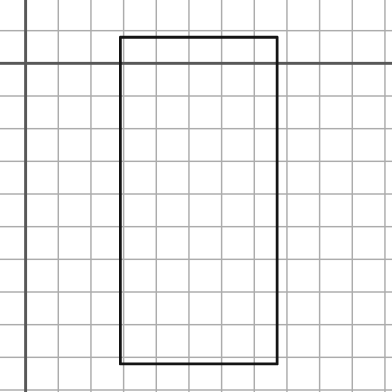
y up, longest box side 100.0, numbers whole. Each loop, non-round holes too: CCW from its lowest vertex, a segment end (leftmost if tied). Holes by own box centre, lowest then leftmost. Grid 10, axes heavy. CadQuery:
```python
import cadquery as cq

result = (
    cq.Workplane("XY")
    .moveTo(29.0, -92.0)
    .lineTo(77.0, -92.0)
    .lineTo(77.0, 8.0)
    .lineTo(29.0, 8.0)
    .close()
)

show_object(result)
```